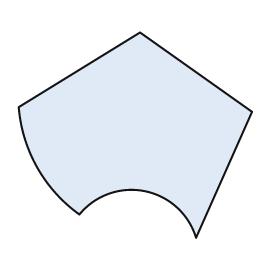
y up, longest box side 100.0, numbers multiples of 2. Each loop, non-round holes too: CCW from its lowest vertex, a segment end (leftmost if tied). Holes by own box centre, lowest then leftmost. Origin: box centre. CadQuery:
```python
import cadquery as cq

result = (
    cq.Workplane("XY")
    .moveTo(26.0, -44.0)
    .lineTo(50.0, 10.0)
    .lineTo(2.0, 44.0)
    .lineTo(-50.0, 12.0)
    .threePointArc((-42.0, -14.0), (-24.0, -34.0))
    .threePointArc((4.0, -24.0), (26.0, -44.0))
    .close()
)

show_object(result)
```